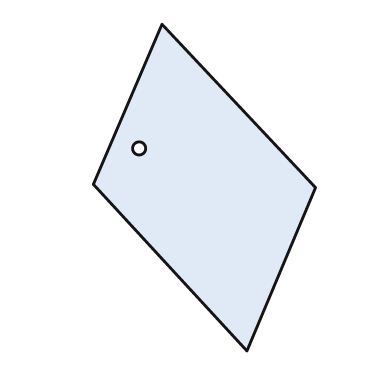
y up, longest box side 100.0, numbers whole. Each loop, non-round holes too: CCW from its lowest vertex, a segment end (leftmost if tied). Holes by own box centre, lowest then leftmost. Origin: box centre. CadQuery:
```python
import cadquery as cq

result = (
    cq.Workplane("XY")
    .moveTo(13.0, -50.0)
    .lineTo(34.0, 0.0)
    .lineTo(-13.0, 50.0)
    .lineTo(-34.0, 1.0)
    .close()
    .moveTo(-20.0, 12.0)
    .circle(2.0)
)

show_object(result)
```